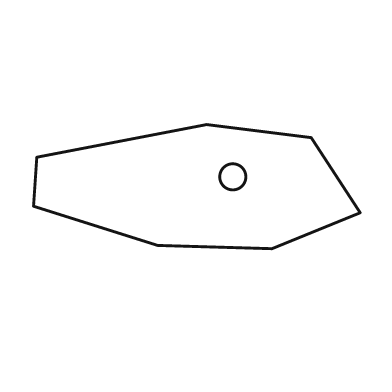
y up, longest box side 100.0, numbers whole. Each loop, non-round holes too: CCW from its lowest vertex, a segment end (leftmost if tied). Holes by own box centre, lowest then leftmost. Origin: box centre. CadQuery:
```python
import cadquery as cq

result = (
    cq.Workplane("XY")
    .moveTo(23.0, -19.0)
    .lineTo(50.0, -8.0)
    .lineTo(35.0, 15.0)
    .lineTo(3.0, 19.0)
    .lineTo(-49.0, 9.0)
    .lineTo(-50.0, -6.0)
    .lineTo(-12.0, -18.0)
    .close()
    .moveTo(11.0, 3.0)
    .circle(4.0)
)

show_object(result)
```